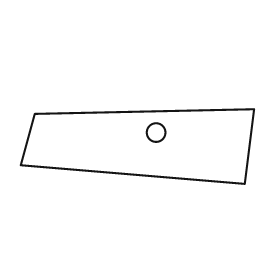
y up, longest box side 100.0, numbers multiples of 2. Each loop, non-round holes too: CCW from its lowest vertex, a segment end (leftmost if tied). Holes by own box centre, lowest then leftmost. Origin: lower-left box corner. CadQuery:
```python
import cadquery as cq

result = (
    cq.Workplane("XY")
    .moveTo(96.0, 0.0)
    .lineTo(100.0, 32.0)
    .lineTo(6.0, 30.0)
    .lineTo(0.0, 8.0)
    .close()
    .moveTo(58.0, 22.0)
    .circle(4.0)
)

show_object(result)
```